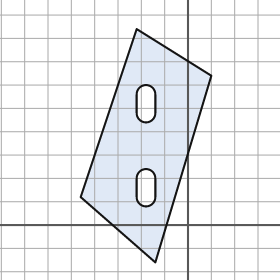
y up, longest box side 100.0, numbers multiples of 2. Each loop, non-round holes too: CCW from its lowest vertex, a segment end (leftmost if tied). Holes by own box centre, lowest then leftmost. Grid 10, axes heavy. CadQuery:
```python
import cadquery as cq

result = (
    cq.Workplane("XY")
    .moveTo(-14.0, -16.0)
    .lineTo(10.0, 64.0)
    .lineTo(-22.0, 84.0)
    .lineTo(-46.0, 12.0)
    .close()
    .moveTo(-22.0, 12.0)
    .threePointArc((-18.0, 8.0), (-14.0, 12.0))
    .lineTo(-14.0, 20.0)
    .threePointArc((-18.0, 24.0), (-22.0, 20.0))
    .close()
    .moveTo(-22.0, 48.0)
    .threePointArc((-18.0, 44.0), (-14.0, 48.0))
    .lineTo(-14.0, 56.0)
    .threePointArc((-18.0, 60.0), (-22.0, 56.0))
    .close()
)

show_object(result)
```